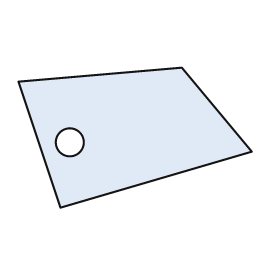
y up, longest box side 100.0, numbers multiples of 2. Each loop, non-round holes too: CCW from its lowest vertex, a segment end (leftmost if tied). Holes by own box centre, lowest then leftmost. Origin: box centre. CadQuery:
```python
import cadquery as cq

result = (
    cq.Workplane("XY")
    .moveTo(-32.0, -30.0)
    .lineTo(50.0, -6.0)
    .lineTo(20.0, 30.0)
    .lineTo(-50.0, 24.0)
    .close()
    .moveTo(-28.0, -2.0)
    .circle(6.0)
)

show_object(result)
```